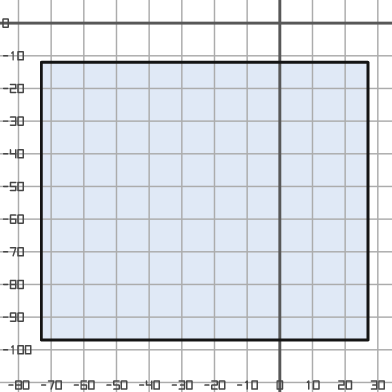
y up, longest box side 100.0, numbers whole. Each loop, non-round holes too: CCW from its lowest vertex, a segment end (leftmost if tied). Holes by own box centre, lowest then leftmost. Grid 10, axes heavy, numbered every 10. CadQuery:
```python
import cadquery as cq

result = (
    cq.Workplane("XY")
    .moveTo(-73.0, -97.0)
    .lineTo(27.0, -97.0)
    .lineTo(27.0, -12.0)
    .lineTo(-73.0, -12.0)
    .close()
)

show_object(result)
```